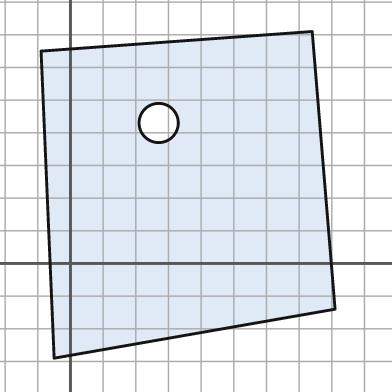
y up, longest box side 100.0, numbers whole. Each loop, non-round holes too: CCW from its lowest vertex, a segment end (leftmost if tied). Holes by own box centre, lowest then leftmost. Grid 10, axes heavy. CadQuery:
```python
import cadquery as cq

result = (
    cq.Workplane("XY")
    .moveTo(-5.0, -29.0)
    .lineTo(81.0, -14.0)
    .lineTo(74.0, 71.0)
    .lineTo(-9.0, 65.0)
    .close()
    .moveTo(27.0, 43.0)
    .circle(6.0)
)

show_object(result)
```